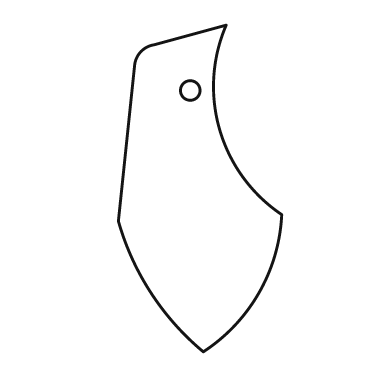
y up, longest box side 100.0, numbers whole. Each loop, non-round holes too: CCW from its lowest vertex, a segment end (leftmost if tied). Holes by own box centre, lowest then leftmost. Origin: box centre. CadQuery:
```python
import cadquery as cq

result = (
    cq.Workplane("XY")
    .moveTo(1.0, -50.0)
    .threePointArc((18.0, -32.0), (25.0, -8.0))
    .threePointArc((6.0, 18.0), (8.0, 50.0))
    .lineTo(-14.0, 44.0)
    .threePointArc((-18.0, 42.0), (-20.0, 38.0))
    .lineTo(-25.0, -10.0)
    .threePointArc((-15.0, -32.0), (1.0, -50.0))
    .close()
    .moveTo(-3.0, 30.0)
    .circle(3.0)
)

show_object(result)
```